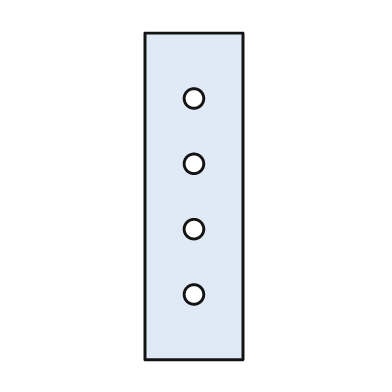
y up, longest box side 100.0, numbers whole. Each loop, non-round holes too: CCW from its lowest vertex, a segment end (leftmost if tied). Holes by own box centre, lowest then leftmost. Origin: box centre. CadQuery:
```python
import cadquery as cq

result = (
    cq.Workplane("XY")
    .moveTo(-15.0, -50.0)
    .lineTo(15.0, -50.0)
    .lineTo(15.0, 50.0)
    .lineTo(-15.0, 50.0)
    .close()
    .moveTo(0.0, -30.0)
    .circle(3.0)
    .moveTo(0.0, -10.0)
    .circle(3.0)
    .moveTo(0.0, 10.0)
    .circle(3.0)
    .moveTo(0.0, 30.0)
    .circle(3.0)
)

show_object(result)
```